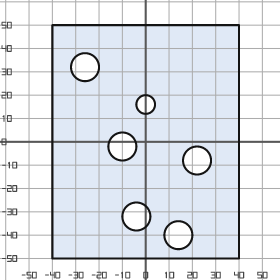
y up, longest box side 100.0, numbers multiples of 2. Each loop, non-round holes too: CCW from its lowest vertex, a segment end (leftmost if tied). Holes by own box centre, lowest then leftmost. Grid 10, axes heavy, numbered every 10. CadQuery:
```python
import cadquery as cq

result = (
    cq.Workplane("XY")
    .moveTo(-40.0, -50.0)
    .lineTo(40.0, -50.0)
    .lineTo(40.0, 50.0)
    .lineTo(-40.0, 50.0)
    .close()
    .moveTo(14.0, -40.0)
    .circle(6.0)
    .moveTo(-4.0, -32.0)
    .circle(6.0)
    .moveTo(22.0, -8.0)
    .circle(6.0)
    .moveTo(-10.0, -2.0)
    .circle(6.0)
    .moveTo(0.0, 16.0)
    .circle(4.0)
    .moveTo(-26.0, 32.0)
    .circle(6.0)
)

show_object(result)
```